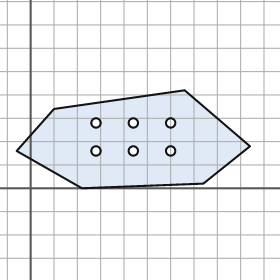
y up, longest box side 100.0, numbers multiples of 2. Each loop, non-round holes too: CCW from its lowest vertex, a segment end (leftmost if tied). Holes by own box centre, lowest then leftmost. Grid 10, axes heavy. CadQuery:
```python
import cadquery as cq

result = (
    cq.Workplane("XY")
    .moveTo(22.0, 0.0)
    .lineTo(74.0, 2.0)
    .lineTo(94.0, 18.0)
    .lineTo(66.0, 42.0)
    .lineTo(10.0, 34.0)
    .lineTo(-6.0, 16.0)
    .close()
    .moveTo(28.0, 16.0)
    .circle(2.0)
    .moveTo(44.0, 16.0)
    .circle(2.0)
    .moveTo(60.0, 16.0)
    .circle(2.0)
    .moveTo(28.0, 28.0)
    .circle(2.0)
    .moveTo(44.0, 28.0)
    .circle(2.0)
    .moveTo(60.0, 28.0)
    .circle(2.0)
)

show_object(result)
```